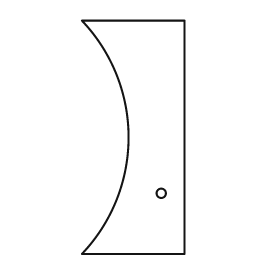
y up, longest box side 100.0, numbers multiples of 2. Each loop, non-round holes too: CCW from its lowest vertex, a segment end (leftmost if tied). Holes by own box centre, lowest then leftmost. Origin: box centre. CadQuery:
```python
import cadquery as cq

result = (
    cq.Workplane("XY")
    .moveTo(-22.0, -50.0)
    .lineTo(22.0, -50.0)
    .lineTo(22.0, 50.0)
    .lineTo(-22.0, 50.0)
    .threePointArc((-2.0, 0.0), (-22.0, -50.0))
    .close()
    .moveTo(12.0, -24.0)
    .circle(2.0)
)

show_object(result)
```